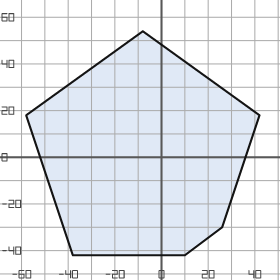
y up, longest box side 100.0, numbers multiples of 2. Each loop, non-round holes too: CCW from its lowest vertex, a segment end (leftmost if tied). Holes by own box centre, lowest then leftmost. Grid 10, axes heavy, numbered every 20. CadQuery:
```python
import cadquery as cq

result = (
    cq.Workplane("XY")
    .moveTo(-38.0, -42.0)
    .lineTo(10.0, -42.0)
    .lineTo(26.0, -30.0)
    .lineTo(42.0, 18.0)
    .lineTo(-8.0, 54.0)
    .lineTo(-58.0, 18.0)
    .close()
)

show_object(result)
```